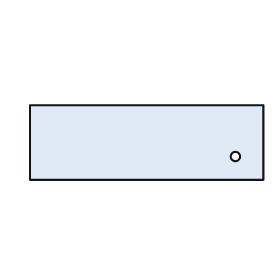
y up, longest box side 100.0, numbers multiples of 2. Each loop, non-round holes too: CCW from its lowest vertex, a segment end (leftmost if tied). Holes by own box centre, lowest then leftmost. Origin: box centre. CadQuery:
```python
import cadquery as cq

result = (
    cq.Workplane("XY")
    .moveTo(-50.0, -16.0)
    .lineTo(50.0, -16.0)
    .lineTo(50.0, 16.0)
    .lineTo(-50.0, 16.0)
    .close()
    .moveTo(38.0, -6.0)
    .circle(2.0)
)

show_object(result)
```